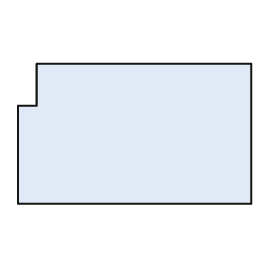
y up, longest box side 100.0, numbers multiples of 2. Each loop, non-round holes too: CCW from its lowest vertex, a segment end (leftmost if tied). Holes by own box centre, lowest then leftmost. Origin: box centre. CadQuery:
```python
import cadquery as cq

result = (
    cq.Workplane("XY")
    .moveTo(-50.0, -30.0)
    .lineTo(50.0, -30.0)
    .lineTo(50.0, 30.0)
    .lineTo(-42.0, 30.0)
    .lineTo(-42.0, 12.0)
    .lineTo(-50.0, 12.0)
    .close()
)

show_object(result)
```